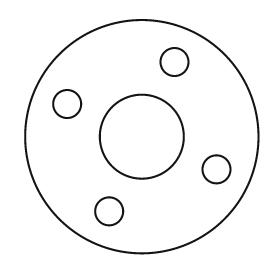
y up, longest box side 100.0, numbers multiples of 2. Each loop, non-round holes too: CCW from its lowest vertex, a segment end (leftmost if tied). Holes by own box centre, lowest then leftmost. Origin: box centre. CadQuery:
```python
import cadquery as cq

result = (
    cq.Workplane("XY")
    .moveTo(0.0, 0.0)
    .circle(50.0)
    .moveTo(-14.0, -32.0)
    .circle(6.0)
    .moveTo(32.0, -14.0)
    .circle(6.0)
    .moveTo(0.0, 0.0)
    .circle(18.0)
    .moveTo(-32.0, 14.0)
    .circle(6.0)
    .moveTo(14.0, 32.0)
    .circle(6.0)
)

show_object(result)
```